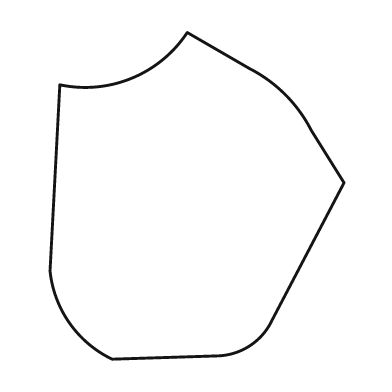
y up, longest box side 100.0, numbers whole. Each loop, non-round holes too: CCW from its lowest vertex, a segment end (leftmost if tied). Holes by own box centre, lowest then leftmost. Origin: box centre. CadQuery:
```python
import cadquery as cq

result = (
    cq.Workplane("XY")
    .moveTo(-26.0, -50.0)
    .lineTo(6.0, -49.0)
    .threePointArc((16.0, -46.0), (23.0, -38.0))
    .lineTo(45.0, 4.0)
    .lineTo(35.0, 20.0)
    .threePointArc((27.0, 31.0), (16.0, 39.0))
    .lineTo(-3.0, 50.0)
    .threePointArc((-20.0, 36.0), (-42.0, 34.0))
    .lineTo(-45.0, -23.0)
    .threePointArc((-39.0, -39.0), (-26.0, -50.0))
    .close()
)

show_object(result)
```